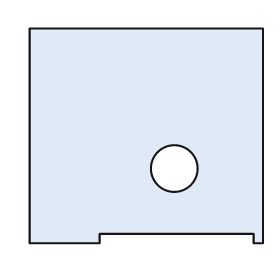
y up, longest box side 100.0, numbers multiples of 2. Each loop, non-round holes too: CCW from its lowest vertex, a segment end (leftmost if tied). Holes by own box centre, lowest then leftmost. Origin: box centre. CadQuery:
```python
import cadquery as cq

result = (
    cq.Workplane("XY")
    .moveTo(-50.0, -46.0)
    .lineTo(-20.0, -46.0)
    .lineTo(-20.0, -42.0)
    .lineTo(46.0, -42.0)
    .lineTo(46.0, -46.0)
    .lineTo(50.0, -46.0)
    .lineTo(50.0, 46.0)
    .lineTo(-50.0, 46.0)
    .close()
    .moveTo(12.0, -14.0)
    .circle(10.0)
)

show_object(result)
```